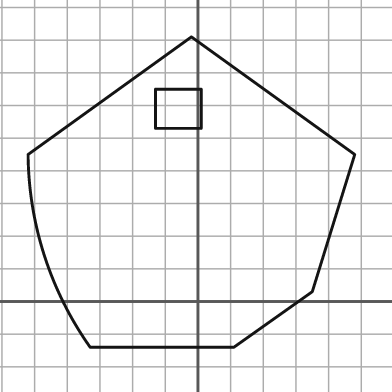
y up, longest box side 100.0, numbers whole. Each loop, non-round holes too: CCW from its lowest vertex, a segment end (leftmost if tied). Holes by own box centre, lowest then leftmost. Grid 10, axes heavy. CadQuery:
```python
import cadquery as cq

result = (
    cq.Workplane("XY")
    .moveTo(-33.0, -14.0)
    .lineTo(11.0, -14.0)
    .lineTo(35.0, 3.0)
    .lineTo(48.0, 45.0)
    .lineTo(-2.0, 81.0)
    .lineTo(-52.0, 45.0)
    .threePointArc((-47.0, 14.0), (-33.0, -14.0))
    .close()
    .moveTo(-13.0, 53.0)
    .lineTo(1.0, 53.0)
    .lineTo(1.0, 65.0)
    .lineTo(-13.0, 65.0)
    .close()
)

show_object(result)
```